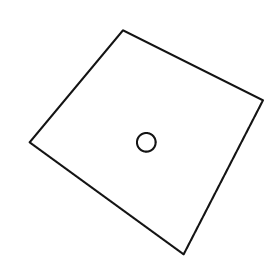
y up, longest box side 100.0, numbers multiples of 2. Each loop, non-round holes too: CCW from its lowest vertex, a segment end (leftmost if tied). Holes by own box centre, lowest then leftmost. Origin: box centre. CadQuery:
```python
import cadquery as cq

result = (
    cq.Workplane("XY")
    .moveTo(16.0, -48.0)
    .lineTo(50.0, 18.0)
    .lineTo(-10.0, 48.0)
    .lineTo(-50.0, 0.0)
    .close()
    .moveTo(0.0, 0.0)
    .circle(4.0)
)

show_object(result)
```